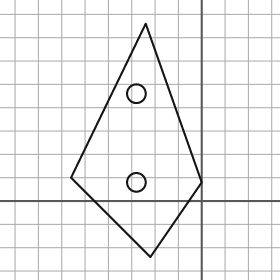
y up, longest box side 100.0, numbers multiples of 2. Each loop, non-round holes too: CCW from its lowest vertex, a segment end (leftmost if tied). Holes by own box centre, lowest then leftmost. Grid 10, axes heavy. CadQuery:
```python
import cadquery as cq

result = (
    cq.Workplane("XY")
    .moveTo(-22.0, -24.0)
    .lineTo(0.0, 8.0)
    .lineTo(-24.0, 76.0)
    .lineTo(-56.0, 10.0)
    .close()
    .moveTo(-28.0, 8.0)
    .circle(4.0)
    .moveTo(-28.0, 46.0)
    .circle(4.0)
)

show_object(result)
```